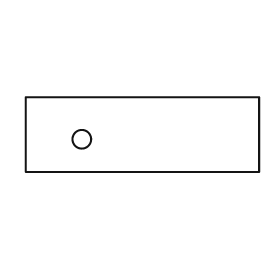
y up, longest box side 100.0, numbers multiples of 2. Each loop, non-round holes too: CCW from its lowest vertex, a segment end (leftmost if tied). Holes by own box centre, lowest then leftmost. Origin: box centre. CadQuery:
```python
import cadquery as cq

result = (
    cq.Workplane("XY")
    .moveTo(-50.0, -16.0)
    .lineTo(50.0, -16.0)
    .lineTo(50.0, 16.0)
    .lineTo(-50.0, 16.0)
    .close()
    .moveTo(-26.0, -2.0)
    .circle(4.0)
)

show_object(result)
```